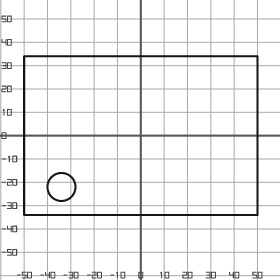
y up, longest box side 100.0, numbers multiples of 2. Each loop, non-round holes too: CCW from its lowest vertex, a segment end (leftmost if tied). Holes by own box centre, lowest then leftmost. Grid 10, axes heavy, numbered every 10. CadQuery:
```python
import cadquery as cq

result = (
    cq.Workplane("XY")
    .moveTo(-50.0, -34.0)
    .lineTo(50.0, -34.0)
    .lineTo(50.0, 34.0)
    .lineTo(-50.0, 34.0)
    .close()
    .moveTo(-34.0, -22.0)
    .circle(6.0)
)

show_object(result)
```